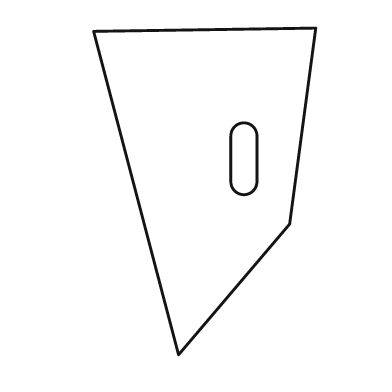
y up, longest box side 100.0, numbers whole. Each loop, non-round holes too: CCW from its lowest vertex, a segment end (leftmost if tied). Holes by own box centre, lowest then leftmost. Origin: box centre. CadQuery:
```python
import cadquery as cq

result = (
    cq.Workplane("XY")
    .moveTo(-8.0, -50.0)
    .lineTo(26.0, -10.0)
    .lineTo(34.0, 50.0)
    .lineTo(-34.0, 49.0)
    .close()
    .moveTo(8.0, 3.0)
    .threePointArc((12.0, -1.0), (16.0, 3.0))
    .lineTo(16.0, 17.0)
    .threePointArc((12.0, 21.0), (8.0, 17.0))
    .close()
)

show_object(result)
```